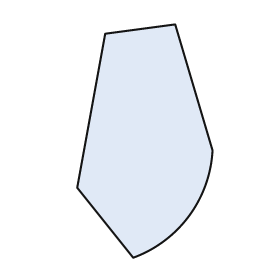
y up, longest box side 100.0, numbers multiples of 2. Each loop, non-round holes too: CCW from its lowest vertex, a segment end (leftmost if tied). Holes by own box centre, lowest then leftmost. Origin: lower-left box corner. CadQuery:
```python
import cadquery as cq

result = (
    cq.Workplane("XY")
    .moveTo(24.0, 0.0)
    .threePointArc((48.0, 18.0), (58.0, 46.0))
    .lineTo(42.0, 100.0)
    .lineTo(12.0, 96.0)
    .lineTo(0.0, 30.0)
    .close()
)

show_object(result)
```